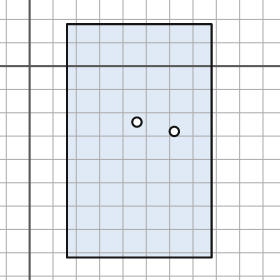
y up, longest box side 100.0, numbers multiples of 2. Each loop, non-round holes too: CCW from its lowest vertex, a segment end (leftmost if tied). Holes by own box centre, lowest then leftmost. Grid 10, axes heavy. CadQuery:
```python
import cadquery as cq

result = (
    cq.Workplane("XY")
    .moveTo(16.0, -82.0)
    .lineTo(78.0, -82.0)
    .lineTo(78.0, 18.0)
    .lineTo(16.0, 18.0)
    .close()
    .moveTo(62.0, -28.0)
    .circle(2.0)
    .moveTo(46.0, -24.0)
    .circle(2.0)
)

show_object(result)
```